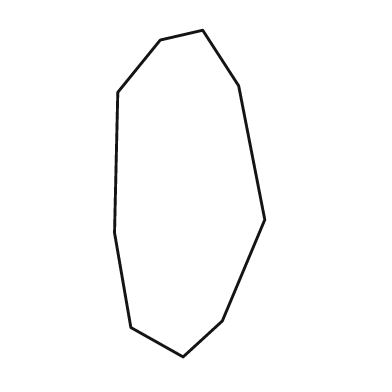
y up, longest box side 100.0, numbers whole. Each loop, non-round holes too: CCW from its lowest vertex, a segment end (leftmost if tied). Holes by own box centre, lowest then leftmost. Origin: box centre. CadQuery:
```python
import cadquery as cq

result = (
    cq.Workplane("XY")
    .moveTo(-2.0, -50.0)
    .lineTo(10.0, -39.0)
    .lineTo(23.0, -8.0)
    .lineTo(15.0, 33.0)
    .lineTo(4.0, 50.0)
    .lineTo(-9.0, 47.0)
    .lineTo(-22.0, 31.0)
    .lineTo(-23.0, -12.0)
    .lineTo(-18.0, -41.0)
    .close()
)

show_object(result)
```